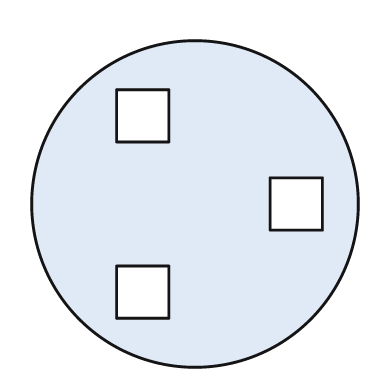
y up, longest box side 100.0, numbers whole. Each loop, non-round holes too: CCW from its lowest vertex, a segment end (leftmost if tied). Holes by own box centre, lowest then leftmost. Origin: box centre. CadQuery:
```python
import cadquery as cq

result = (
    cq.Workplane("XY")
    .moveTo(0.0, 0.0)
    .circle(50.0)
    .moveTo(-24.0, -35.0)
    .lineTo(-8.0, -35.0)
    .lineTo(-8.0, -19.0)
    .lineTo(-24.0, -19.0)
    .close()
    .moveTo(23.0, -8.0)
    .lineTo(39.0, -8.0)
    .lineTo(39.0, 8.0)
    .lineTo(23.0, 8.0)
    .close()
    .moveTo(-24.0, 19.0)
    .lineTo(-8.0, 19.0)
    .lineTo(-8.0, 35.0)
    .lineTo(-24.0, 35.0)
    .close()
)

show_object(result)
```